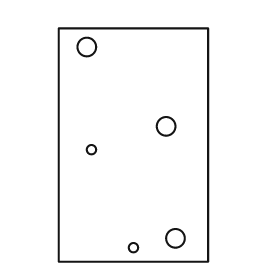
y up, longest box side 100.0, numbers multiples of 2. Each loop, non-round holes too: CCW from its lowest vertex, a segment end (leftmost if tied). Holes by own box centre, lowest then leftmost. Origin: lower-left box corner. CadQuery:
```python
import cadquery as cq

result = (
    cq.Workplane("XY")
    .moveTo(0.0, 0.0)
    .lineTo(64.0, 0.0)
    .lineTo(64.0, 100.0)
    .lineTo(0.0, 100.0)
    .close()
    .moveTo(32.0, 6.0)
    .circle(2.0)
    .moveTo(50.0, 10.0)
    .circle(4.0)
    .moveTo(14.0, 48.0)
    .circle(2.0)
    .moveTo(46.0, 58.0)
    .circle(4.0)
    .moveTo(12.0, 92.0)
    .circle(4.0)
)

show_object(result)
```